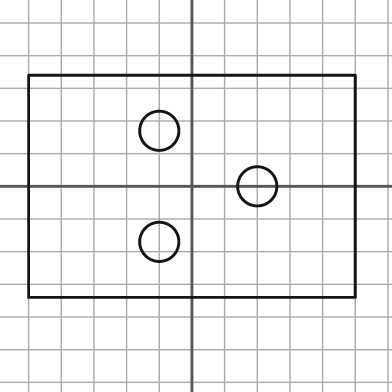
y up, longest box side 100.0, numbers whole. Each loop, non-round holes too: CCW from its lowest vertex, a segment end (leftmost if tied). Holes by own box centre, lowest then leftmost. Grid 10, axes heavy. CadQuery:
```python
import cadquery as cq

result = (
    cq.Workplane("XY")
    .moveTo(-50.0, -34.0)
    .lineTo(50.0, -34.0)
    .lineTo(50.0, 34.0)
    .lineTo(-50.0, 34.0)
    .close()
    .moveTo(-10.0, -17.0)
    .circle(6.0)
    .moveTo(20.0, 0.0)
    .circle(6.0)
    .moveTo(-10.0, 17.0)
    .circle(6.0)
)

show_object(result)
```